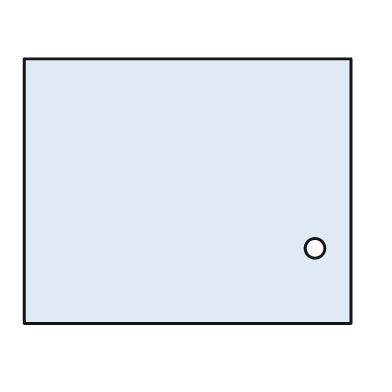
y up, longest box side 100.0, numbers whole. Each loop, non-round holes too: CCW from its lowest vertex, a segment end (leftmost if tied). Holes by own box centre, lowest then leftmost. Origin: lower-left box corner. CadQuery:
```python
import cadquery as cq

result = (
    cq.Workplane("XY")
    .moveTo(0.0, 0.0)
    .lineTo(100.0, 0.0)
    .lineTo(100.0, 81.0)
    .lineTo(0.0, 81.0)
    .close()
    .moveTo(89.0, 23.0)
    .circle(3.0)
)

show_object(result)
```